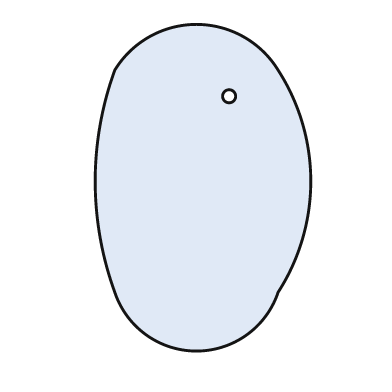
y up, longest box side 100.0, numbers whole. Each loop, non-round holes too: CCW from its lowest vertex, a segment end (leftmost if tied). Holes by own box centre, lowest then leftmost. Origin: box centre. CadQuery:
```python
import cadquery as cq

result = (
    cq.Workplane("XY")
    .moveTo(-27.0, -32.0)
    .threePointArc((-2.0, -50.0), (23.0, -32.0))
    .threePointArc((33.0, 2.0), (23.0, 36.0))
    .threePointArc((-2.0, 50.0), (-27.0, 36.0))
    .threePointArc((-33.0, 2.0), (-27.0, -32.0))
    .close()
    .moveTo(8.0, 28.0)
    .circle(2.0)
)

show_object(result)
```